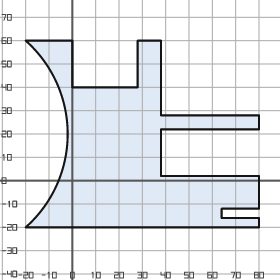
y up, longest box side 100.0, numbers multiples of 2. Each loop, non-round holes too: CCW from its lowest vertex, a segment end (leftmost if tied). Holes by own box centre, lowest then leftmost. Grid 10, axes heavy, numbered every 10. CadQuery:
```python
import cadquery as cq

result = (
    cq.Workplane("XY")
    .moveTo(-20.0, -20.0)
    .lineTo(80.0, -20.0)
    .lineTo(80.0, -16.0)
    .lineTo(64.0, -16.0)
    .lineTo(64.0, -12.0)
    .lineTo(80.0, -12.0)
    .lineTo(80.0, 2.0)
    .lineTo(38.0, 2.0)
    .lineTo(38.0, 22.0)
    .lineTo(80.0, 22.0)
    .lineTo(80.0, 28.0)
    .lineTo(38.0, 28.0)
    .lineTo(38.0, 60.0)
    .lineTo(28.0, 60.0)
    .lineTo(28.0, 40.0)
    .lineTo(0.0, 40.0)
    .lineTo(0.0, 60.0)
    .lineTo(-20.0, 60.0)
    .threePointArc((-2.0, 20.0), (-20.0, -20.0))
    .close()
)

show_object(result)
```